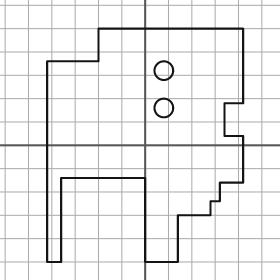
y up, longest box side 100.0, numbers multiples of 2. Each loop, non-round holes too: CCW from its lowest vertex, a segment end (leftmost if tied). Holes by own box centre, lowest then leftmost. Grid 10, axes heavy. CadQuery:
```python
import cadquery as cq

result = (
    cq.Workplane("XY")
    .moveTo(-42.0, -50.0)
    .lineTo(-36.0, -50.0)
    .lineTo(-36.0, -14.0)
    .lineTo(0.0, -14.0)
    .lineTo(0.0, -50.0)
    .lineTo(14.0, -50.0)
    .lineTo(14.0, -30.0)
    .lineTo(28.0, -30.0)
    .lineTo(28.0, -24.0)
    .lineTo(32.0, -24.0)
    .lineTo(32.0, -16.0)
    .lineTo(42.0, -16.0)
    .lineTo(42.0, 4.0)
    .lineTo(34.0, 4.0)
    .lineTo(34.0, 18.0)
    .lineTo(42.0, 18.0)
    .lineTo(42.0, 50.0)
    .lineTo(-20.0, 50.0)
    .lineTo(-20.0, 36.0)
    .lineTo(-42.0, 36.0)
    .close()
    .moveTo(8.0, 16.0)
    .circle(4.0)
    .moveTo(8.0, 32.0)
    .circle(4.0)
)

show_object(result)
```